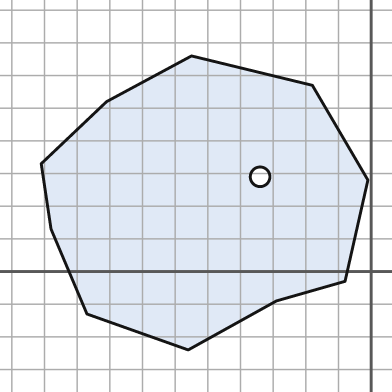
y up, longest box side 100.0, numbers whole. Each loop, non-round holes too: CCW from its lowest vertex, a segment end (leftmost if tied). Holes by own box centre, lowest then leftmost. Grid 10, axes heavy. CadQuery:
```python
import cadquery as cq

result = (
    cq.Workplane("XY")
    .moveTo(-56.0, -24.0)
    .lineTo(-29.0, -9.0)
    .lineTo(-8.0, -3.0)
    .lineTo(-1.0, 28.0)
    .lineTo(-18.0, 57.0)
    .lineTo(-55.0, 66.0)
    .lineTo(-81.0, 52.0)
    .lineTo(-101.0, 33.0)
    .lineTo(-98.0, 13.0)
    .lineTo(-87.0, -13.0)
    .close()
    .moveTo(-34.0, 29.0)
    .circle(3.0)
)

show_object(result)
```